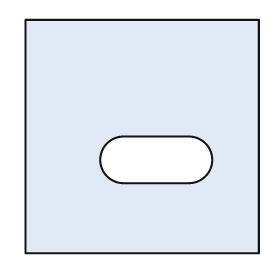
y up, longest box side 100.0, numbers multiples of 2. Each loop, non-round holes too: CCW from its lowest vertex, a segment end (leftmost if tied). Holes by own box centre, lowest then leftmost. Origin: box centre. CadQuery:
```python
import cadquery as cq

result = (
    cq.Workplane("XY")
    .moveTo(-50.0, -50.0)
    .lineTo(50.0, -50.0)
    .lineTo(50.0, 50.0)
    .lineTo(-50.0, 50.0)
    .close()
    .moveTo(-8.0, -20.0)
    .lineTo(20.0, -20.0)
    .threePointArc((30.0, -10.0), (20.0, 0.0))
    .lineTo(-8.0, 0.0)
    .threePointArc((-18.0, -10.0), (-8.0, -20.0))
    .close()
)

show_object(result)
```